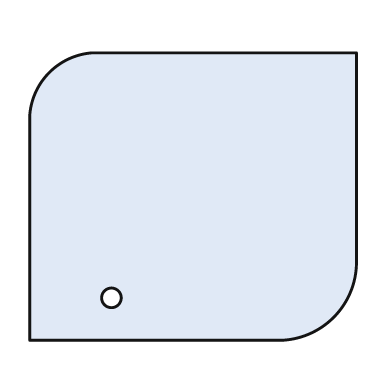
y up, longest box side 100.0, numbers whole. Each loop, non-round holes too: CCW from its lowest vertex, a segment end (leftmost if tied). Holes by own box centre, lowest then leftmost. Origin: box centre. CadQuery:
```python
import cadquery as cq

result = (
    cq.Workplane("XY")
    .moveTo(-50.0, -44.0)
    .lineTo(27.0, -44.0)
    .threePointArc((43.0, -37.0), (50.0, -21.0))
    .lineTo(50.0, 44.0)
    .lineTo(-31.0, 44.0)
    .threePointArc((-44.0, 38.0), (-50.0, 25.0))
    .close()
    .moveTo(-25.0, -31.0)
    .circle(3.0)
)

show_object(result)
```